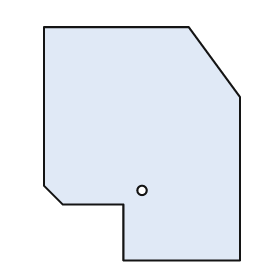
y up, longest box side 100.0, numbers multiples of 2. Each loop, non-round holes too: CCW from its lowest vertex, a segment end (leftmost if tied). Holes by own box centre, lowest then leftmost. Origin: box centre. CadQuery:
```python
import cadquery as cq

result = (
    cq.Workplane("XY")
    .moveTo(-8.0, -50.0)
    .lineTo(42.0, -50.0)
    .lineTo(42.0, 20.0)
    .lineTo(20.0, 50.0)
    .lineTo(-42.0, 50.0)
    .lineTo(-42.0, -18.0)
    .lineTo(-34.0, -26.0)
    .lineTo(-8.0, -26.0)
    .close()
    .moveTo(0.0, -20.0)
    .circle(2.0)
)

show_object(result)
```